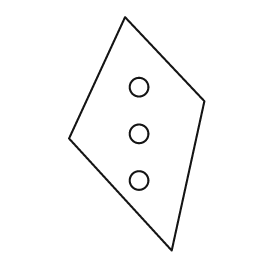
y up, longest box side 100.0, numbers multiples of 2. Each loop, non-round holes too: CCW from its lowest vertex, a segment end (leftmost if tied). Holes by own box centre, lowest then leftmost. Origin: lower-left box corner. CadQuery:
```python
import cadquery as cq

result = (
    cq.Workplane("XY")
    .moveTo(44.0, 0.0)
    .lineTo(58.0, 64.0)
    .lineTo(24.0, 100.0)
    .lineTo(0.0, 48.0)
    .close()
    .moveTo(30.0, 30.0)
    .circle(4.0)
    .moveTo(30.0, 50.0)
    .circle(4.0)
    .moveTo(30.0, 70.0)
    .circle(4.0)
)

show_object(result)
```